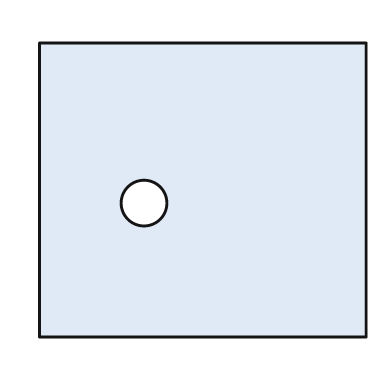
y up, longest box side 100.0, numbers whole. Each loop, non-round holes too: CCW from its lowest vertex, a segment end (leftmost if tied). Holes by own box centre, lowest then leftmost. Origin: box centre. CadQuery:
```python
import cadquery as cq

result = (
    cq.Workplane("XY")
    .moveTo(-50.0, -45.0)
    .lineTo(50.0, -45.0)
    .lineTo(50.0, 45.0)
    .lineTo(-50.0, 45.0)
    .close()
    .moveTo(-18.0, -4.0)
    .circle(7.0)
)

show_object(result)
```